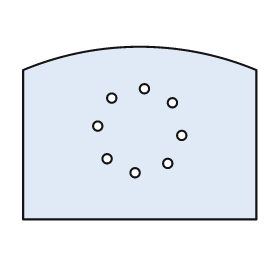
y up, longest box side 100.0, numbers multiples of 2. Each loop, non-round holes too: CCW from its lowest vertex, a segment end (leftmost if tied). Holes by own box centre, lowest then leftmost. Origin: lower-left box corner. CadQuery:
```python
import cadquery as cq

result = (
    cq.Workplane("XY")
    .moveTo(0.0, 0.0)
    .lineTo(100.0, 0.0)
    .lineTo(100.0, 64.0)
    .threePointArc((50.0, 74.0), (0.0, 64.0))
    .close()
    .moveTo(48.0, 20.0)
    .circle(2.0)
    .moveTo(62.0, 24.0)
    .circle(2.0)
    .moveTo(36.0, 26.0)
    .circle(2.0)
    .moveTo(68.0, 36.0)
    .circle(2.0)
    .moveTo(32.0, 40.0)
    .circle(2.0)
    .moveTo(64.0, 50.0)
    .circle(2.0)
    .moveTo(38.0, 52.0)
    .circle(2.0)
    .moveTo(52.0, 56.0)
    .circle(2.0)
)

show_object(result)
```